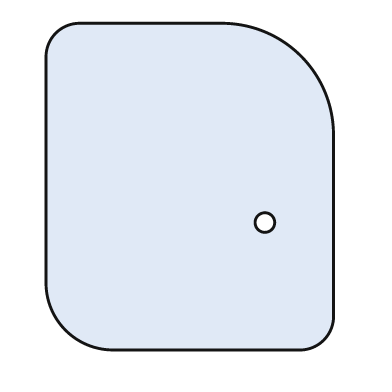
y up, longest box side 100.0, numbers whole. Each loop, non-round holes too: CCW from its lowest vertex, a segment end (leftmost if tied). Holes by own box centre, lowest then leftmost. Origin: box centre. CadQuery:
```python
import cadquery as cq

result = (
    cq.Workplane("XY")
    .moveTo(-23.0, -50.0)
    .lineTo(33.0, -50.0)
    .threePointArc((41.0, -47.0), (44.0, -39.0))
    .lineTo(44.0, 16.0)
    .threePointArc((34.0, 40.0), (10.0, 50.0))
    .lineTo(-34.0, 50.0)
    .threePointArc((-41.0, 47.0), (-44.0, 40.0))
    .lineTo(-44.0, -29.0)
    .threePointArc((-38.0, -44.0), (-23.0, -50.0))
    .close()
    .moveTo(23.0, -11.0)
    .circle(3.0)
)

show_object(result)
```